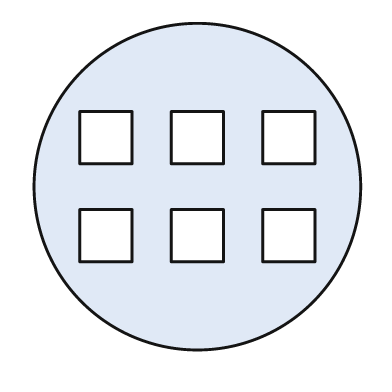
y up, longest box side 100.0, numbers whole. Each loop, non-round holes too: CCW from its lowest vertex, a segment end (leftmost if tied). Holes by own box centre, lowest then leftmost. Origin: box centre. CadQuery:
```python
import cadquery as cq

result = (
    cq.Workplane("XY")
    .moveTo(0.0, 0.0)
    .circle(50.0)
    .moveTo(-36.0, -23.0)
    .lineTo(-20.0, -23.0)
    .lineTo(-20.0, -7.0)
    .lineTo(-36.0, -7.0)
    .close()
    .moveTo(-8.0, -23.0)
    .lineTo(8.0, -23.0)
    .lineTo(8.0, -7.0)
    .lineTo(-8.0, -7.0)
    .close()
    .moveTo(20.0, -23.0)
    .lineTo(36.0, -23.0)
    .lineTo(36.0, -7.0)
    .lineTo(20.0, -7.0)
    .close()
    .moveTo(-36.0, 7.0)
    .lineTo(-20.0, 7.0)
    .lineTo(-20.0, 23.0)
    .lineTo(-36.0, 23.0)
    .close()
    .moveTo(-8.0, 7.0)
    .lineTo(8.0, 7.0)
    .lineTo(8.0, 23.0)
    .lineTo(-8.0, 23.0)
    .close()
    .moveTo(20.0, 7.0)
    .lineTo(36.0, 7.0)
    .lineTo(36.0, 23.0)
    .lineTo(20.0, 23.0)
    .close()
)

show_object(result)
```